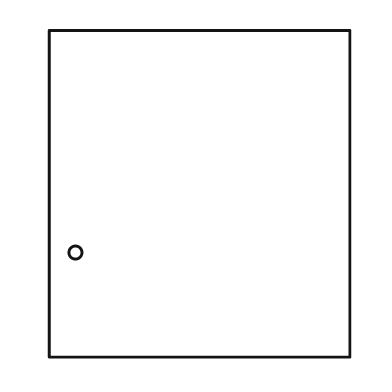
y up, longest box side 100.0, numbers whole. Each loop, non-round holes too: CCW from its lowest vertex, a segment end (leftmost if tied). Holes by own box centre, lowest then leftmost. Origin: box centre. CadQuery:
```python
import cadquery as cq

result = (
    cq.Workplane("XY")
    .moveTo(-46.0, -50.0)
    .lineTo(46.0, -50.0)
    .lineTo(46.0, 50.0)
    .lineTo(-46.0, 50.0)
    .close()
    .moveTo(-38.0, -18.0)
    .circle(2.0)
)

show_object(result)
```